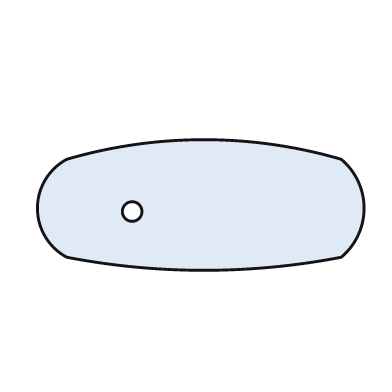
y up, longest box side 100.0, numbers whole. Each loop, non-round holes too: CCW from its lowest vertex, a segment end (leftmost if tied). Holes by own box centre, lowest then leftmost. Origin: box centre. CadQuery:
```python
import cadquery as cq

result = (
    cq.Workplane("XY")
    .moveTo(-41.0, -16.0)
    .threePointArc((1.0, -20.0), (43.0, -16.0))
    .threePointArc((50.0, -1.0), (43.0, 14.0))
    .threePointArc((1.0, 20.0), (-41.0, 14.0))
    .threePointArc((-50.0, -1.0), (-41.0, -16.0))
    .close()
    .moveTo(-21.0, -2.0)
    .circle(3.0)
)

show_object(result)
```